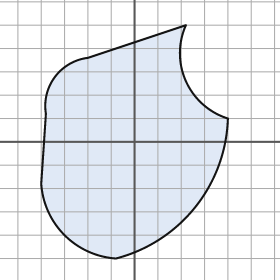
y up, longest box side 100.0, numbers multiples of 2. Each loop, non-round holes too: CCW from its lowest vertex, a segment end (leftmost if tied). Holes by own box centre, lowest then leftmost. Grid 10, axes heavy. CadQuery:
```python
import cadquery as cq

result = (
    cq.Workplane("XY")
    .moveTo(-8.0, -50.0)
    .threePointArc((26.0, -28.0), (40.0, 10.0))
    .threePointArc((22.0, 26.0), (22.0, 50.0))
    .lineTo(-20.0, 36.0)
    .threePointArc((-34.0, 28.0), (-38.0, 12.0))
    .lineTo(-40.0, -18.0)
    .threePointArc((-30.0, -40.0), (-8.0, -50.0))
    .close()
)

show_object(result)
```